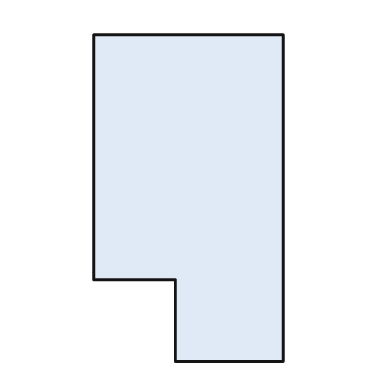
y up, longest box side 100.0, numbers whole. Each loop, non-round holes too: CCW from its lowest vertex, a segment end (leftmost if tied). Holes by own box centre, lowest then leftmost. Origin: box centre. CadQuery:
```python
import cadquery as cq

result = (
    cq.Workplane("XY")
    .moveTo(-4.0, -50.0)
    .lineTo(29.0, -50.0)
    .lineTo(29.0, 50.0)
    .lineTo(-29.0, 50.0)
    .lineTo(-29.0, -25.0)
    .lineTo(-4.0, -25.0)
    .close()
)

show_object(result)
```